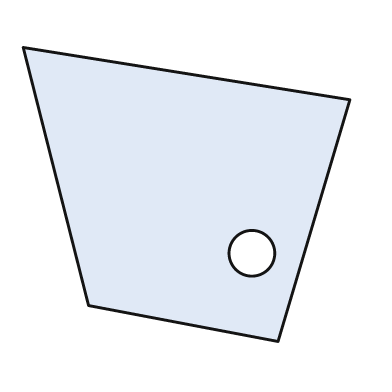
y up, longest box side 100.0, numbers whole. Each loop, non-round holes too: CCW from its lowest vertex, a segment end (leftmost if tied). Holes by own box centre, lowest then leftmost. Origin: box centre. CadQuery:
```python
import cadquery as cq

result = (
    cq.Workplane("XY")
    .moveTo(28.0, -45.0)
    .lineTo(50.0, 29.0)
    .lineTo(-50.0, 45.0)
    .lineTo(-30.0, -34.0)
    .close()
    .moveTo(20.0, -18.0)
    .circle(7.0)
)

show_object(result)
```